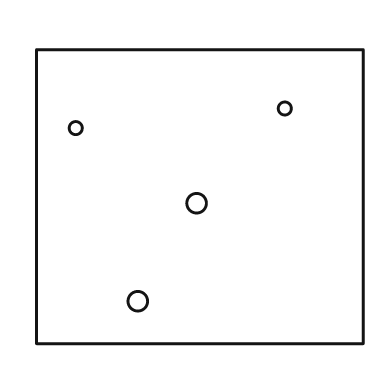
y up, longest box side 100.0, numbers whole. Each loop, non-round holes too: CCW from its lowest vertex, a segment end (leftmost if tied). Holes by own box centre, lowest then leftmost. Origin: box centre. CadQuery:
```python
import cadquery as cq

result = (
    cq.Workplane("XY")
    .moveTo(-50.0, -45.0)
    .lineTo(50.0, -45.0)
    .lineTo(50.0, 45.0)
    .lineTo(-50.0, 45.0)
    .close()
    .moveTo(-19.0, -32.0)
    .circle(3.0)
    .moveTo(-1.0, -2.0)
    .circle(3.0)
    .moveTo(-38.0, 21.0)
    .circle(2.0)
    .moveTo(26.0, 27.0)
    .circle(2.0)
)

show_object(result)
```